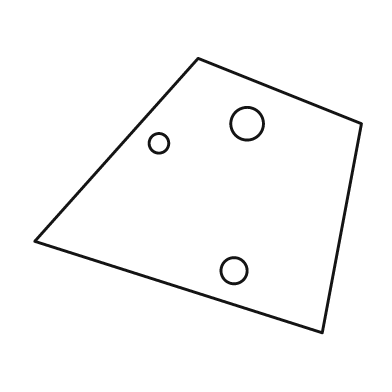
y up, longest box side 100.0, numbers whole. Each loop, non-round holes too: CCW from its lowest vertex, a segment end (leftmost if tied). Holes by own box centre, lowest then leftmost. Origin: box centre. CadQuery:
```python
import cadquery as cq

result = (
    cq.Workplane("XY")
    .moveTo(38.0, -42.0)
    .lineTo(50.0, 22.0)
    .lineTo(0.0, 42.0)
    .lineTo(-50.0, -14.0)
    .close()
    .moveTo(11.0, -23.0)
    .circle(4.0)
    .moveTo(-12.0, 16.0)
    .circle(3.0)
    .moveTo(15.0, 22.0)
    .circle(5.0)
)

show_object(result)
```